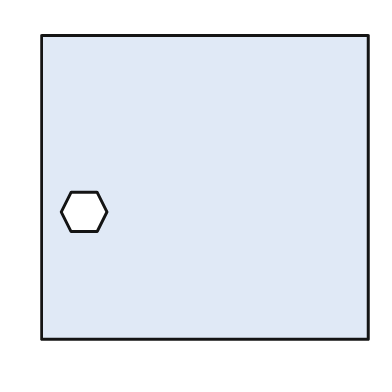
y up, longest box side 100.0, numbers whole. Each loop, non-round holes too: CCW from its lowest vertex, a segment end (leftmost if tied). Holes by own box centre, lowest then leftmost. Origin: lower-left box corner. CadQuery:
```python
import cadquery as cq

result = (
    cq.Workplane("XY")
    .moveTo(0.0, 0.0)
    .lineTo(100.0, 0.0)
    .lineTo(100.0, 93.0)
    .lineTo(0.0, 93.0)
    .close()
    .moveTo(9.0, 33.0)
    .lineTo(17.0, 33.0)
    .lineTo(20.0, 39.0)
    .lineTo(17.0, 45.0)
    .lineTo(9.0, 45.0)
    .lineTo(6.0, 39.0)
    .close()
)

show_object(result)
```